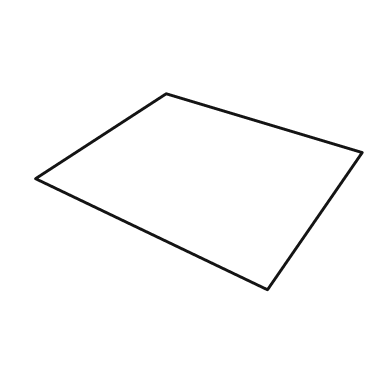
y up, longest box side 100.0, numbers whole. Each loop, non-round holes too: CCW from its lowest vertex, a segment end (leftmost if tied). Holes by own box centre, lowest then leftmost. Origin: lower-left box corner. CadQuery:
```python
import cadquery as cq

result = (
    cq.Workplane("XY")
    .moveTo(71.0, 0.0)
    .lineTo(100.0, 42.0)
    .lineTo(40.0, 60.0)
    .lineTo(0.0, 34.0)
    .close()
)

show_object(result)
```